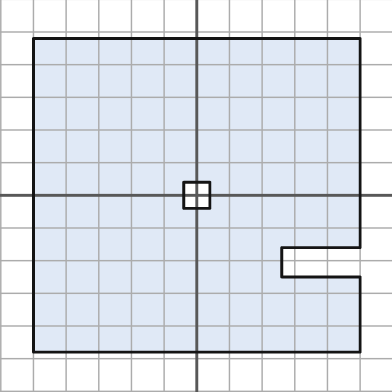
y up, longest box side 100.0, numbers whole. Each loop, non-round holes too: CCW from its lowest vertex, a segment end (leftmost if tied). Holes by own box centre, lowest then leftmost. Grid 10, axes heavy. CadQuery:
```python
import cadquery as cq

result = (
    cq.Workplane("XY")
    .moveTo(-50.0, -48.0)
    .lineTo(50.0, -48.0)
    .lineTo(50.0, -25.0)
    .lineTo(26.0, -25.0)
    .lineTo(26.0, -16.0)
    .lineTo(50.0, -16.0)
    .lineTo(50.0, 48.0)
    .lineTo(-50.0, 48.0)
    .close()
    .moveTo(-4.0, -4.0)
    .lineTo(4.0, -4.0)
    .lineTo(4.0, 4.0)
    .lineTo(-4.0, 4.0)
    .close()
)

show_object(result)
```